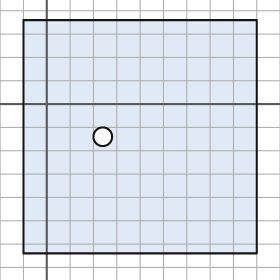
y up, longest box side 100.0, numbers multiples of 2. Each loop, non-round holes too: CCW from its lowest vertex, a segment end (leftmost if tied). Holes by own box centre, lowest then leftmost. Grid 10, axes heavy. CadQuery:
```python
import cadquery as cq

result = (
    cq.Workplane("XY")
    .moveTo(-10.0, -64.0)
    .lineTo(90.0, -64.0)
    .lineTo(90.0, 36.0)
    .lineTo(-10.0, 36.0)
    .close()
    .moveTo(24.0, -14.0)
    .circle(4.0)
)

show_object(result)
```